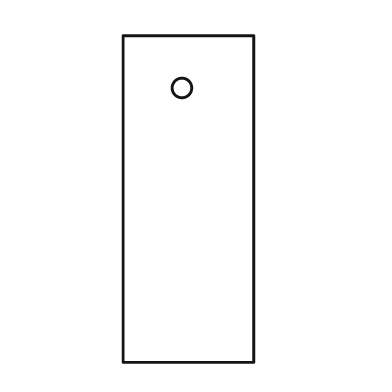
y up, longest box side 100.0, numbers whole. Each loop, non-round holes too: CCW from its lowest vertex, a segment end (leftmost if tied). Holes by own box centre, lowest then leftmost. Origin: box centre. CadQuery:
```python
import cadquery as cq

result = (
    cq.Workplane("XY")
    .moveTo(-20.0, -50.0)
    .lineTo(20.0, -50.0)
    .lineTo(20.0, 50.0)
    .lineTo(-20.0, 50.0)
    .close()
    .moveTo(-2.0, 34.0)
    .circle(3.0)
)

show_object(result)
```